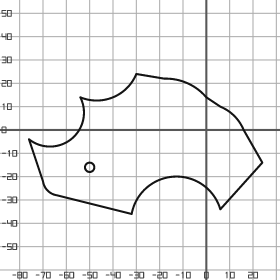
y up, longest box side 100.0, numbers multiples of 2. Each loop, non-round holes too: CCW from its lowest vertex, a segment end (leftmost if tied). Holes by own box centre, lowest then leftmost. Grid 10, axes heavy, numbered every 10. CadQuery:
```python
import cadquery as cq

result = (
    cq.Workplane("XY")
    .moveTo(-32.0, -36.0)
    .threePointArc((-14.0, -20.0), (6.0, -34.0))
    .lineTo(24.0, -14.0)
    .lineTo(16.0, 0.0)
    .threePointArc((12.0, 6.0), (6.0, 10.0))
    .lineTo(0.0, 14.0)
    .threePointArc((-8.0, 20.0), (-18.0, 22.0))
    .lineTo(-30.0, 24.0)
    .threePointArc((-40.0, 14.0), (-54.0, 14.0))
    .threePointArc((-58.0, -4.0), (-76.0, -4.0))
    .lineTo(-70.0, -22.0)
    .threePointArc((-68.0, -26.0), (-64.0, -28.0))
    .close()
    .moveTo(-50.0, -16.0)
    .circle(2.0)
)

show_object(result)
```